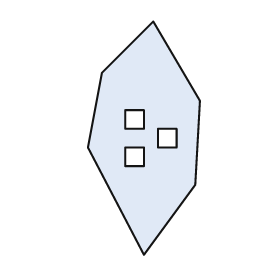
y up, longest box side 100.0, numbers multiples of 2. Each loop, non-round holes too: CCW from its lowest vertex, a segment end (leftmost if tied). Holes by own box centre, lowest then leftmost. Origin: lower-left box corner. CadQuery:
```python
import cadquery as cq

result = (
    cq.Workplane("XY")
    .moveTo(24.0, 0.0)
    .lineTo(46.0, 30.0)
    .lineTo(48.0, 66.0)
    .lineTo(28.0, 100.0)
    .lineTo(6.0, 78.0)
    .lineTo(0.0, 46.0)
    .close()
    .moveTo(16.0, 38.0)
    .lineTo(24.0, 38.0)
    .lineTo(24.0, 46.0)
    .lineTo(16.0, 46.0)
    .close()
    .moveTo(30.0, 46.0)
    .lineTo(38.0, 46.0)
    .lineTo(38.0, 54.0)
    .lineTo(30.0, 54.0)
    .close()
    .moveTo(16.0, 54.0)
    .lineTo(24.0, 54.0)
    .lineTo(24.0, 62.0)
    .lineTo(16.0, 62.0)
    .close()
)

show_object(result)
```